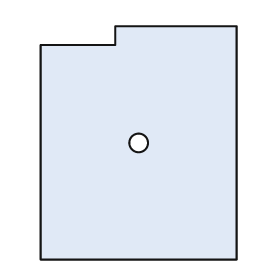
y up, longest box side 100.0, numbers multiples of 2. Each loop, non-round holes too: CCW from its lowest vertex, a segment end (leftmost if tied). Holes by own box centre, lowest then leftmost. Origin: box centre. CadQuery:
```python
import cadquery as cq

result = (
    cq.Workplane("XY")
    .moveTo(-42.0, -50.0)
    .lineTo(42.0, -50.0)
    .lineTo(42.0, 50.0)
    .lineTo(-10.0, 50.0)
    .lineTo(-10.0, 42.0)
    .lineTo(-42.0, 42.0)
    .close()
    .moveTo(0.0, 0.0)
    .circle(4.0)
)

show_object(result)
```